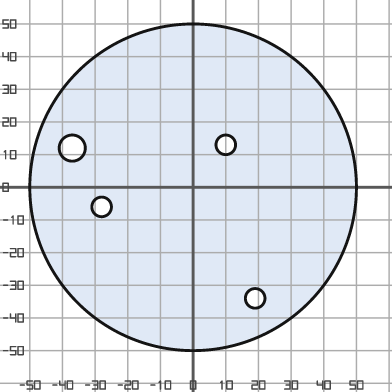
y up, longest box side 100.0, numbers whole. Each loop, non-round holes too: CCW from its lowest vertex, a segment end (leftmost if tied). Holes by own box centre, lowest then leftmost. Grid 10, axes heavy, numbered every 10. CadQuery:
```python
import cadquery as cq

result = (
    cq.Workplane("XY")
    .moveTo(0.0, 0.0)
    .circle(50.0)
    .moveTo(19.0, -34.0)
    .circle(3.0)
    .moveTo(-28.0, -6.0)
    .circle(3.0)
    .moveTo(-37.0, 12.0)
    .circle(4.0)
    .moveTo(10.0, 13.0)
    .circle(3.0)
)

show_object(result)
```